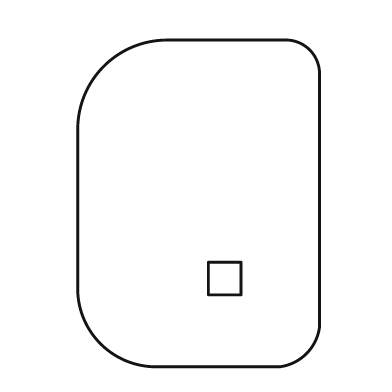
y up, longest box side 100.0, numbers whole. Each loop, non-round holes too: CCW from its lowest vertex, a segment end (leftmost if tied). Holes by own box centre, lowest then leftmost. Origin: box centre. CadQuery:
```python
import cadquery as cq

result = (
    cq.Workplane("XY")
    .moveTo(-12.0, -50.0)
    .lineTo(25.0, -50.0)
    .threePointArc((33.0, -46.0), (37.0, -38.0))
    .lineTo(37.0, 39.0)
    .threePointArc((34.0, 47.0), (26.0, 50.0))
    .lineTo(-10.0, 50.0)
    .threePointArc((-29.0, 42.0), (-37.0, 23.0))
    .lineTo(-37.0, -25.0)
    .threePointArc((-30.0, -43.0), (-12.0, -50.0))
    .close()
    .moveTo(3.0, -28.0)
    .lineTo(13.0, -28.0)
    .lineTo(13.0, -18.0)
    .lineTo(3.0, -18.0)
    .close()
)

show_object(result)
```